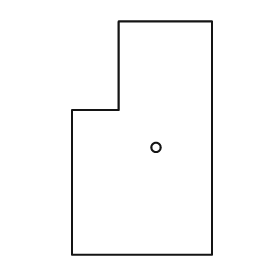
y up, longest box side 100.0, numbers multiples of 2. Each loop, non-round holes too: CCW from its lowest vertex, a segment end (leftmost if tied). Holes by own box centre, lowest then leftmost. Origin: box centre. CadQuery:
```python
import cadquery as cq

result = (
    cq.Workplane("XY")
    .moveTo(-30.0, -50.0)
    .lineTo(30.0, -50.0)
    .lineTo(30.0, 50.0)
    .lineTo(-10.0, 50.0)
    .lineTo(-10.0, 12.0)
    .lineTo(-30.0, 12.0)
    .close()
    .moveTo(6.0, -4.0)
    .circle(2.0)
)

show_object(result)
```